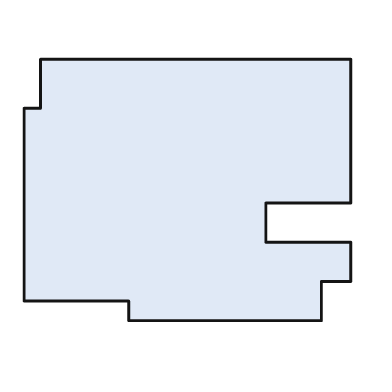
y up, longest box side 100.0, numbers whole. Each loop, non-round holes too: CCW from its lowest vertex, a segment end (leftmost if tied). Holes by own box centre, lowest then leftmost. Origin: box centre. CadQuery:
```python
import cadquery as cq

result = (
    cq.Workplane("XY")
    .moveTo(-18.0, -40.0)
    .lineTo(41.0, -40.0)
    .lineTo(41.0, -28.0)
    .lineTo(50.0, -28.0)
    .lineTo(50.0, -16.0)
    .lineTo(24.0, -16.0)
    .lineTo(24.0, -4.0)
    .lineTo(50.0, -4.0)
    .lineTo(50.0, 40.0)
    .lineTo(-45.0, 40.0)
    .lineTo(-45.0, 25.0)
    .lineTo(-50.0, 25.0)
    .lineTo(-50.0, -34.0)
    .lineTo(-18.0, -34.0)
    .close()
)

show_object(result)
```